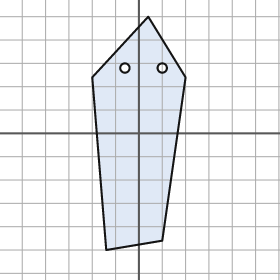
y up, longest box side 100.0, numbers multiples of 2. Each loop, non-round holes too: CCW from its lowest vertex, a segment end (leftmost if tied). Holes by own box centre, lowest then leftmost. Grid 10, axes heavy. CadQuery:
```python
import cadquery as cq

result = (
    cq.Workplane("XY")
    .moveTo(-14.0, -50.0)
    .lineTo(10.0, -46.0)
    .lineTo(20.0, 24.0)
    .lineTo(4.0, 50.0)
    .lineTo(-20.0, 24.0)
    .close()
    .moveTo(-6.0, 28.0)
    .circle(2.0)
    .moveTo(10.0, 28.0)
    .circle(2.0)
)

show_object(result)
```